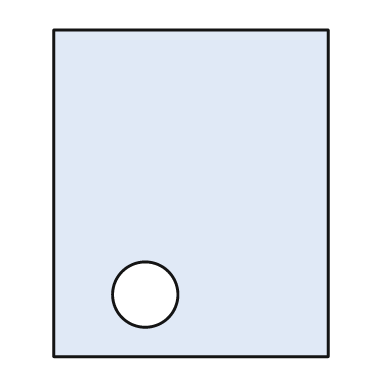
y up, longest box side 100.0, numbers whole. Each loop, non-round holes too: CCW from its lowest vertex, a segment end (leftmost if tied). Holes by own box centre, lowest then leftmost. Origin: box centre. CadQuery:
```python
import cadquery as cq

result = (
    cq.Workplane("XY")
    .moveTo(-42.0, -50.0)
    .lineTo(42.0, -50.0)
    .lineTo(42.0, 50.0)
    .lineTo(-42.0, 50.0)
    .close()
    .moveTo(-14.0, -31.0)
    .circle(10.0)
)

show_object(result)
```